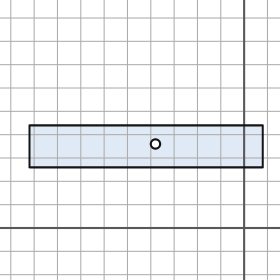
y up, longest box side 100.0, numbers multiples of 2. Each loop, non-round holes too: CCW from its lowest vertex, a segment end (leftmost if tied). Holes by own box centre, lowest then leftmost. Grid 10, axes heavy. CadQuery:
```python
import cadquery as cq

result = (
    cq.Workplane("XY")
    .moveTo(-92.0, 26.0)
    .lineTo(8.0, 26.0)
    .lineTo(8.0, 44.0)
    .lineTo(-92.0, 44.0)
    .close()
    .moveTo(-38.0, 36.0)
    .circle(2.0)
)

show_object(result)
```